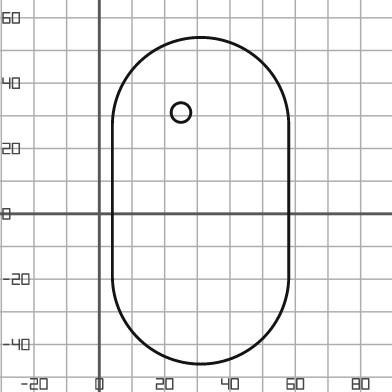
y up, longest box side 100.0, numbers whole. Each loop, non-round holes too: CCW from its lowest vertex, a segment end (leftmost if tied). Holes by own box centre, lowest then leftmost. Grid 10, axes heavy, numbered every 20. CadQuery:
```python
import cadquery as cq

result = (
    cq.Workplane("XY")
    .moveTo(4.0, -19.0)
    .threePointArc((31.0, -46.0), (58.0, -19.0))
    .lineTo(58.0, 27.0)
    .threePointArc((31.0, 54.0), (4.0, 27.0))
    .close()
    .moveTo(25.0, 31.0)
    .circle(3.0)
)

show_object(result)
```